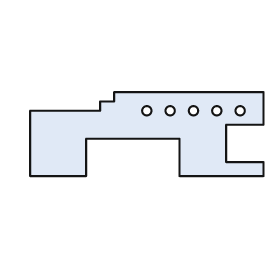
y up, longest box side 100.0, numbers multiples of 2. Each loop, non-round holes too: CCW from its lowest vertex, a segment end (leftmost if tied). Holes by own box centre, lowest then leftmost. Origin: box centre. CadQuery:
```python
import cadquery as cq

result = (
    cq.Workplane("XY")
    .moveTo(-50.0, -18.0)
    .lineTo(-26.0, -18.0)
    .lineTo(-26.0, -2.0)
    .lineTo(14.0, -2.0)
    .lineTo(14.0, -18.0)
    .lineTo(50.0, -18.0)
    .lineTo(50.0, -12.0)
    .lineTo(34.0, -12.0)
    .lineTo(34.0, 4.0)
    .lineTo(50.0, 4.0)
    .lineTo(50.0, 18.0)
    .lineTo(-14.0, 18.0)
    .lineTo(-14.0, 14.0)
    .lineTo(-20.0, 14.0)
    .lineTo(-20.0, 10.0)
    .lineTo(-50.0, 10.0)
    .close()
    .moveTo(0.0, 10.0)
    .circle(2.0)
    .moveTo(10.0, 10.0)
    .circle(2.0)
    .moveTo(20.0, 10.0)
    .circle(2.0)
    .moveTo(30.0, 10.0)
    .circle(2.0)
    .moveTo(40.0, 10.0)
    .circle(2.0)
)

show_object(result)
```